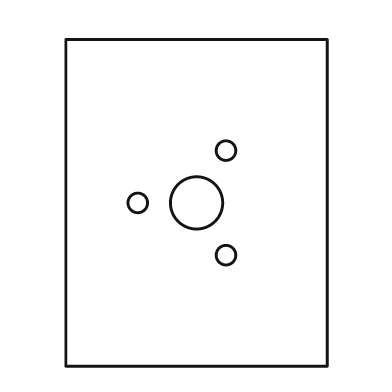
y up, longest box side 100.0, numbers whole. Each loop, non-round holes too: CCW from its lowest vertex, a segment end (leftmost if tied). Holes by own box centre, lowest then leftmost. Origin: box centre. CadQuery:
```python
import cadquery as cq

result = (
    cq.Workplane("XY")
    .moveTo(-40.0, -50.0)
    .lineTo(40.0, -50.0)
    .lineTo(40.0, 50.0)
    .lineTo(-40.0, 50.0)
    .close()
    .moveTo(9.0, -16.0)
    .circle(3.0)
    .moveTo(-18.0, 0.0)
    .circle(3.0)
    .moveTo(0.0, 0.0)
    .circle(8.0)
    .moveTo(9.0, 16.0)
    .circle(3.0)
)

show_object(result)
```